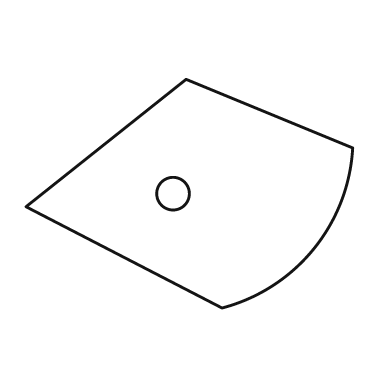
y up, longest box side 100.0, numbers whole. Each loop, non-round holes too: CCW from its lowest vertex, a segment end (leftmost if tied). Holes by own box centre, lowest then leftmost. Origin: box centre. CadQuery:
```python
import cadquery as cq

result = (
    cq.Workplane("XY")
    .moveTo(10.0, -35.0)
    .threePointArc((38.0, -17.0), (50.0, 14.0))
    .lineTo(-1.0, 35.0)
    .lineTo(-50.0, -4.0)
    .close()
    .moveTo(-5.0, 0.0)
    .circle(5.0)
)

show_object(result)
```